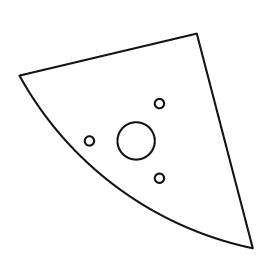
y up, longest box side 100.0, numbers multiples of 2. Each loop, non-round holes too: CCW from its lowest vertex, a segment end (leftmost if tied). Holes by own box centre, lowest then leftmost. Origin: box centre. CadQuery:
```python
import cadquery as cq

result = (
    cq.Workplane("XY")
    .moveTo(50.0, -46.0)
    .lineTo(26.0, 46.0)
    .lineTo(-50.0, 28.0)
    .threePointArc((-8.0, -20.0), (50.0, -46.0))
    .close()
    .moveTo(10.0, -16.0)
    .circle(2.0)
    .moveTo(-20.0, 0.0)
    .circle(2.0)
    .moveTo(0.0, 0.0)
    .circle(8.0)
    .moveTo(10.0, 16.0)
    .circle(2.0)
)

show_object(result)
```